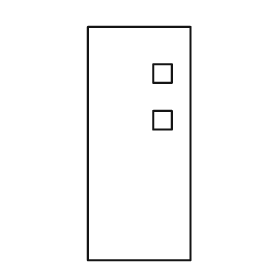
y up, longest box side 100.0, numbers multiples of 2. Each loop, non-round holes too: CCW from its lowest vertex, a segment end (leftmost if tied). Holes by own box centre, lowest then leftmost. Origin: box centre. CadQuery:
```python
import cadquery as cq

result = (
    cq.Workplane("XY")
    .moveTo(-22.0, -50.0)
    .lineTo(22.0, -50.0)
    .lineTo(22.0, 50.0)
    .lineTo(-22.0, 50.0)
    .close()
    .moveTo(6.0, 6.0)
    .lineTo(14.0, 6.0)
    .lineTo(14.0, 14.0)
    .lineTo(6.0, 14.0)
    .close()
    .moveTo(6.0, 26.0)
    .lineTo(14.0, 26.0)
    .lineTo(14.0, 34.0)
    .lineTo(6.0, 34.0)
    .close()
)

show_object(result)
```